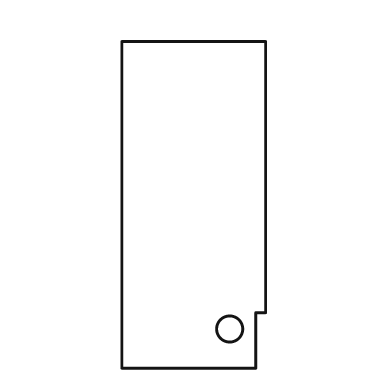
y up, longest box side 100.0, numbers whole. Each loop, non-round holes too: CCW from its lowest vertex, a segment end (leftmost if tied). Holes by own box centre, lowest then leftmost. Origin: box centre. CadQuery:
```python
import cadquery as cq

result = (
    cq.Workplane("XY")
    .moveTo(-22.0, -50.0)
    .lineTo(19.0, -50.0)
    .lineTo(19.0, -33.0)
    .lineTo(22.0, -33.0)
    .lineTo(22.0, 50.0)
    .lineTo(-22.0, 50.0)
    .close()
    .moveTo(11.0, -38.0)
    .circle(4.0)
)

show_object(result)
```